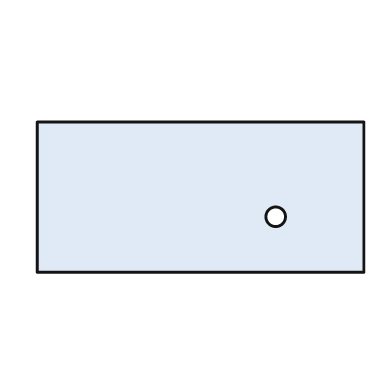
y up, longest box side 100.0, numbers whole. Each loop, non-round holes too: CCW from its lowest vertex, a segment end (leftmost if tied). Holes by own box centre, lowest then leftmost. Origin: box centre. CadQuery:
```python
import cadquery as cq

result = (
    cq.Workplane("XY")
    .moveTo(-50.0, -23.0)
    .lineTo(50.0, -23.0)
    .lineTo(50.0, 23.0)
    .lineTo(-50.0, 23.0)
    .close()
    .moveTo(23.0, -6.0)
    .circle(3.0)
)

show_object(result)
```